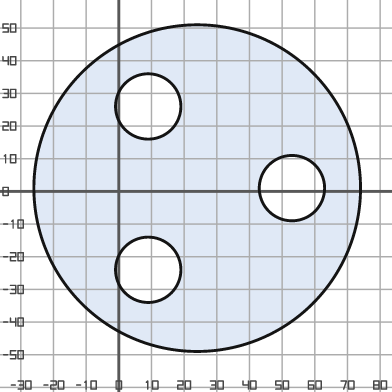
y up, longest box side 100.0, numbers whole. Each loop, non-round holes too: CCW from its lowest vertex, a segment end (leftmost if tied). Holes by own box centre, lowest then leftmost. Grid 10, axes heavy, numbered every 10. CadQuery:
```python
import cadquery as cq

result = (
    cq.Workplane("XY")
    .moveTo(24.0, 1.0)
    .circle(50.0)
    .moveTo(9.0, -24.0)
    .circle(10.0)
    .moveTo(53.0, 1.0)
    .circle(10.0)
    .moveTo(9.0, 26.0)
    .circle(10.0)
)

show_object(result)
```